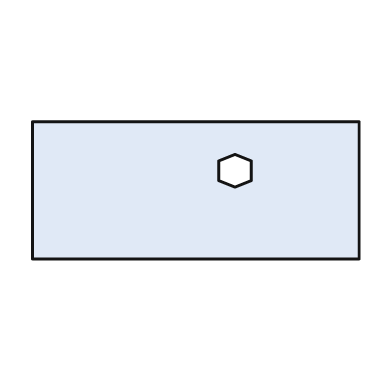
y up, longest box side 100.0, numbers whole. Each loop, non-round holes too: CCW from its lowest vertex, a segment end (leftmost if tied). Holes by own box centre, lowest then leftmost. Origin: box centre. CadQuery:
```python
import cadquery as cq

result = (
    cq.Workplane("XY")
    .moveTo(-50.0, -21.0)
    .lineTo(50.0, -21.0)
    .lineTo(50.0, 21.0)
    .lineTo(-50.0, 21.0)
    .close()
    .moveTo(12.0, 1.0)
    .lineTo(17.0, 3.0)
    .lineTo(17.0, 9.0)
    .lineTo(12.0, 11.0)
    .lineTo(7.0, 9.0)
    .lineTo(7.0, 3.0)
    .close()
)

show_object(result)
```